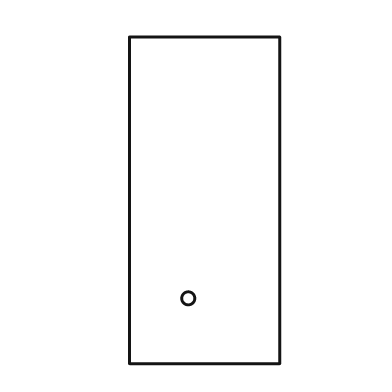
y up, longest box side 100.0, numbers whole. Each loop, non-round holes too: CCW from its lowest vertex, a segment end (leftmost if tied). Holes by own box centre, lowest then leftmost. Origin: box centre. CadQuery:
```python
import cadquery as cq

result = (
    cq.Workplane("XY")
    .moveTo(-23.0, -50.0)
    .lineTo(23.0, -50.0)
    .lineTo(23.0, 50.0)
    .lineTo(-23.0, 50.0)
    .close()
    .moveTo(-5.0, -30.0)
    .circle(2.0)
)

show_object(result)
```